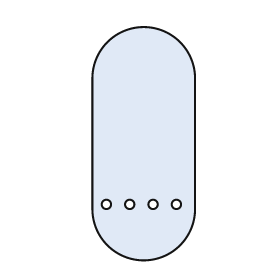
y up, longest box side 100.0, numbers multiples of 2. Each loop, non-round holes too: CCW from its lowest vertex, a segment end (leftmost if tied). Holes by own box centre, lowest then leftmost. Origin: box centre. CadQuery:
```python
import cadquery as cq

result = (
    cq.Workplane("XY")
    .moveTo(-22.0, -28.0)
    .threePointArc((0.0, -50.0), (22.0, -28.0))
    .lineTo(22.0, 28.0)
    .threePointArc((0.0, 50.0), (-22.0, 28.0))
    .close()
    .moveTo(-16.0, -26.0)
    .circle(2.0)
    .moveTo(-6.0, -26.0)
    .circle(2.0)
    .moveTo(4.0, -26.0)
    .circle(2.0)
    .moveTo(14.0, -26.0)
    .circle(2.0)
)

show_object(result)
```